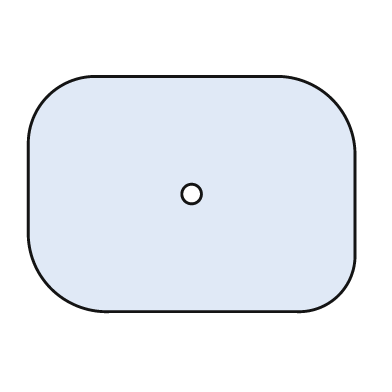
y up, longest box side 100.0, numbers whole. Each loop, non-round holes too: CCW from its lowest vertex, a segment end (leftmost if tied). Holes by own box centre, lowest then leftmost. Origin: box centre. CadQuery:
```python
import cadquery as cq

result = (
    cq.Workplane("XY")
    .moveTo(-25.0, -36.0)
    .lineTo(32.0, -36.0)
    .threePointArc((45.0, -31.0), (50.0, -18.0))
    .lineTo(50.0, 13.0)
    .threePointArc((43.0, 29.0), (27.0, 36.0))
    .lineTo(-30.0, 36.0)
    .threePointArc((-44.0, 30.0), (-50.0, 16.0))
    .lineTo(-50.0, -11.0)
    .threePointArc((-43.0, -29.0), (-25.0, -36.0))
    .close()
    .moveTo(0.0, 0.0)
    .circle(3.0)
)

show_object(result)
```